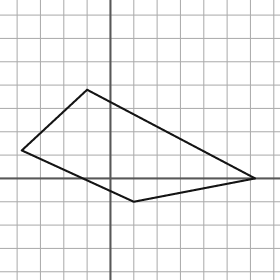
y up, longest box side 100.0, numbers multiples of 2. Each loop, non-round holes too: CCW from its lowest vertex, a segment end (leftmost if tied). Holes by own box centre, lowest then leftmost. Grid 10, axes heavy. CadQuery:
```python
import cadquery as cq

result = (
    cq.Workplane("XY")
    .moveTo(10.0, -10.0)
    .lineTo(62.0, 0.0)
    .lineTo(-10.0, 38.0)
    .lineTo(-38.0, 12.0)
    .close()
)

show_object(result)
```